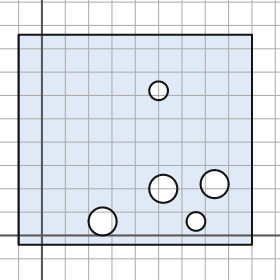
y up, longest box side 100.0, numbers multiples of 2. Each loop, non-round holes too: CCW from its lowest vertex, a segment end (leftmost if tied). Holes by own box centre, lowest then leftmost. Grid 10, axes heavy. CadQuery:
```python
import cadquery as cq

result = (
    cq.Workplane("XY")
    .moveTo(-10.0, -4.0)
    .lineTo(90.0, -4.0)
    .lineTo(90.0, 86.0)
    .lineTo(-10.0, 86.0)
    .close()
    .moveTo(26.0, 6.0)
    .circle(6.0)
    .moveTo(66.0, 6.0)
    .circle(4.0)
    .moveTo(52.0, 20.0)
    .circle(6.0)
    .moveTo(74.0, 22.0)
    .circle(6.0)
    .moveTo(50.0, 62.0)
    .circle(4.0)
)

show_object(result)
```